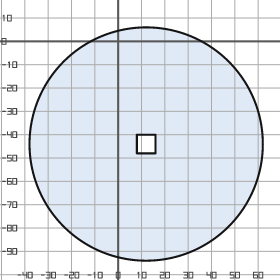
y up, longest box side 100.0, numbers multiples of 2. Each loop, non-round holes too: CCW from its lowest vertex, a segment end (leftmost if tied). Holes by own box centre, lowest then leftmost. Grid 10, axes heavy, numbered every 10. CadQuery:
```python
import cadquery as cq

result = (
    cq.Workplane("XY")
    .moveTo(12.0, -44.0)
    .circle(50.0)
    .moveTo(8.0, -48.0)
    .lineTo(16.0, -48.0)
    .lineTo(16.0, -40.0)
    .lineTo(8.0, -40.0)
    .close()
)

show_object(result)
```